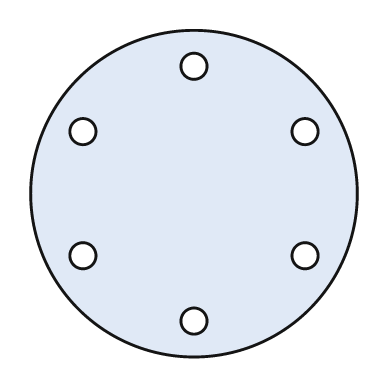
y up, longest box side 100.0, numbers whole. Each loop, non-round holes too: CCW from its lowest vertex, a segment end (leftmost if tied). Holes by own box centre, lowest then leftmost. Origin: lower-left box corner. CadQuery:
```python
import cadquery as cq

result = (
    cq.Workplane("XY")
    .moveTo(50.0, 50.0)
    .circle(50.0)
    .moveTo(50.0, 11.0)
    .circle(4.0)
    .moveTo(16.0, 31.0)
    .circle(4.0)
    .moveTo(84.0, 31.0)
    .circle(4.0)
    .moveTo(16.0, 69.0)
    .circle(4.0)
    .moveTo(84.0, 69.0)
    .circle(4.0)
    .moveTo(50.0, 89.0)
    .circle(4.0)
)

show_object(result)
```